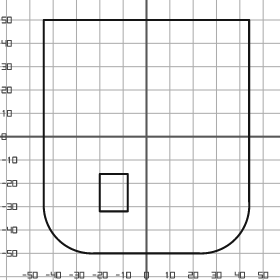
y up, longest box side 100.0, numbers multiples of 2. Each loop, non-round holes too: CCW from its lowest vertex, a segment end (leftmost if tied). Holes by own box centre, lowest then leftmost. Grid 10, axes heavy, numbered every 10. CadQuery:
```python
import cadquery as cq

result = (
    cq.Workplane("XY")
    .moveTo(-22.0, -50.0)
    .lineTo(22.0, -50.0)
    .threePointArc((38.0, -44.0), (44.0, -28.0))
    .lineTo(44.0, 50.0)
    .lineTo(-44.0, 50.0)
    .lineTo(-44.0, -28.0)
    .threePointArc((-38.0, -44.0), (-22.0, -50.0))
    .close()
    .moveTo(-20.0, -32.0)
    .lineTo(-8.0, -32.0)
    .lineTo(-8.0, -16.0)
    .lineTo(-20.0, -16.0)
    .close()
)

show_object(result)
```